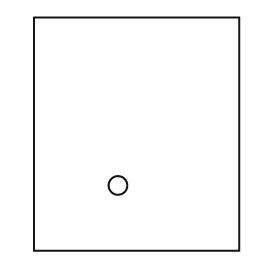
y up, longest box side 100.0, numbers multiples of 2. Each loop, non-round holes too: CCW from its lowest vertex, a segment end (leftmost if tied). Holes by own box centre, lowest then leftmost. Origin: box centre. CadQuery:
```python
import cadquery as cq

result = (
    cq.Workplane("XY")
    .moveTo(-44.0, -50.0)
    .lineTo(44.0, -50.0)
    .lineTo(44.0, 50.0)
    .lineTo(-44.0, 50.0)
    .close()
    .moveTo(-8.0, -22.0)
    .circle(4.0)
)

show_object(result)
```